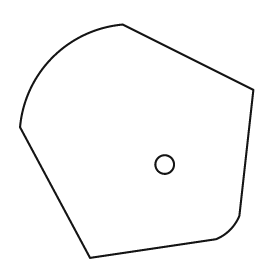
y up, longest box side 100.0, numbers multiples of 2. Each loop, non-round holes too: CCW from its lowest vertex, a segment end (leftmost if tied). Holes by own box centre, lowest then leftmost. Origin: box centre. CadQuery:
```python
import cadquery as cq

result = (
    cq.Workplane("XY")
    .moveTo(-20.0, -50.0)
    .lineTo(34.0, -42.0)
    .threePointArc((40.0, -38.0), (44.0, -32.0))
    .lineTo(50.0, 22.0)
    .lineTo(-6.0, 50.0)
    .threePointArc((-36.0, 36.0), (-50.0, 6.0))
    .close()
    .moveTo(12.0, -10.0)
    .circle(4.0)
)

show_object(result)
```